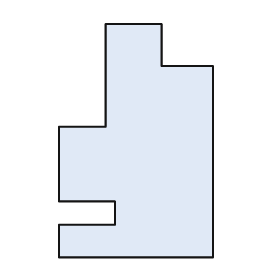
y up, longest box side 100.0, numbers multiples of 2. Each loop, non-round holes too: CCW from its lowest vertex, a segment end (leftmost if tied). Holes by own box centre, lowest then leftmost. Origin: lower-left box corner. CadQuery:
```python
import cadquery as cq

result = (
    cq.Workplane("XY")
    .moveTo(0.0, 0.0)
    .lineTo(66.0, 0.0)
    .lineTo(66.0, 82.0)
    .lineTo(44.0, 82.0)
    .lineTo(44.0, 100.0)
    .lineTo(20.0, 100.0)
    .lineTo(20.0, 56.0)
    .lineTo(0.0, 56.0)
    .lineTo(0.0, 24.0)
    .lineTo(24.0, 24.0)
    .lineTo(24.0, 14.0)
    .lineTo(0.0, 14.0)
    .close()
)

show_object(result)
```